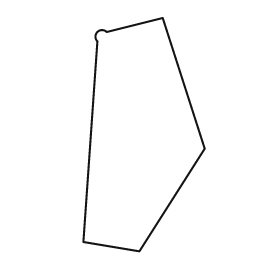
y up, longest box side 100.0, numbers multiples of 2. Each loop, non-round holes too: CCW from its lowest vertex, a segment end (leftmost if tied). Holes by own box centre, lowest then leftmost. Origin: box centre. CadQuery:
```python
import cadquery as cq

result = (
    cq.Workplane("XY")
    .moveTo(-2.0, -50.0)
    .lineTo(26.0, -6.0)
    .lineTo(8.0, 50.0)
    .lineTo(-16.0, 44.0)
    .threePointArc((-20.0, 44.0), (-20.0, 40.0))
    .lineTo(-26.0, -46.0)
    .close()
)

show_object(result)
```